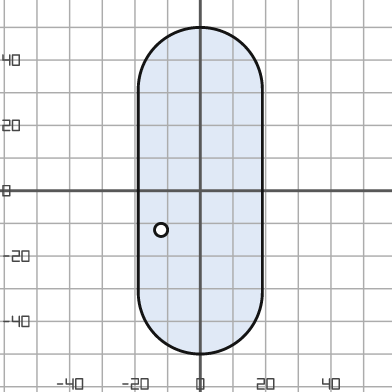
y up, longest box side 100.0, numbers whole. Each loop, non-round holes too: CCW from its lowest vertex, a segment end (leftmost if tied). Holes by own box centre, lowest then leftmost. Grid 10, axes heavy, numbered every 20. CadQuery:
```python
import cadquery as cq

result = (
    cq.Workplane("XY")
    .moveTo(-19.0, -31.0)
    .threePointArc((0.0, -50.0), (19.0, -31.0))
    .lineTo(19.0, 31.0)
    .threePointArc((0.0, 50.0), (-19.0, 31.0))
    .close()
    .moveTo(-12.0, -12.0)
    .circle(2.0)
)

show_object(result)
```